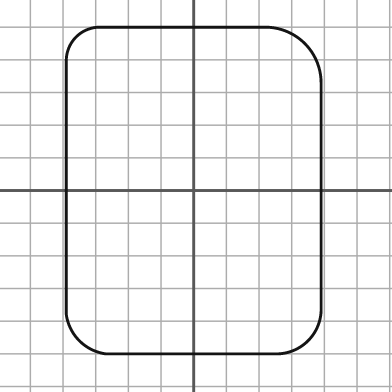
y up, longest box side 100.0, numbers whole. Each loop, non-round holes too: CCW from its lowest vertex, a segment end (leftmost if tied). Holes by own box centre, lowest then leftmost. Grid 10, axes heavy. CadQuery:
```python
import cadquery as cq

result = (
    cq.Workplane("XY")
    .moveTo(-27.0, -50.0)
    .lineTo(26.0, -50.0)
    .threePointArc((35.0, -46.0), (39.0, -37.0))
    .lineTo(39.0, 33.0)
    .threePointArc((34.0, 45.0), (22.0, 50.0))
    .lineTo(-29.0, 50.0)
    .threePointArc((-36.0, 47.0), (-39.0, 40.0))
    .lineTo(-39.0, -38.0)
    .threePointArc((-35.0, -46.0), (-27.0, -50.0))
    .close()
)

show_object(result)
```